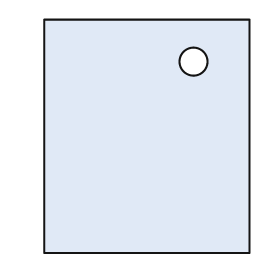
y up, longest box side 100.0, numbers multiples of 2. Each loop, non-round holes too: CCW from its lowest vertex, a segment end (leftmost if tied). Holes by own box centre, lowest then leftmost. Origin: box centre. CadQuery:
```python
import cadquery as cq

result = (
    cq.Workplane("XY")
    .moveTo(-44.0, -50.0)
    .lineTo(44.0, -50.0)
    .lineTo(44.0, 50.0)
    .lineTo(-44.0, 50.0)
    .close()
    .moveTo(20.0, 32.0)
    .circle(6.0)
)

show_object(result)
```